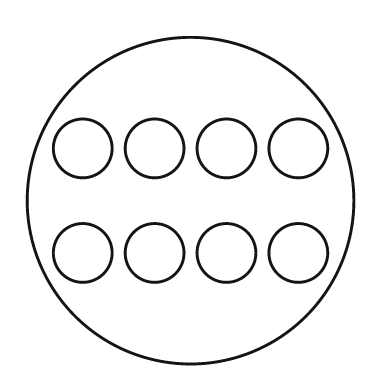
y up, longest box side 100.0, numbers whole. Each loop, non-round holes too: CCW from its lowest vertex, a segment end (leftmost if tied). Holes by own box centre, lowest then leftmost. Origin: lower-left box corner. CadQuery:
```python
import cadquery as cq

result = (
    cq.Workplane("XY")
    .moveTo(50.0, 50.0)
    .circle(50.0)
    .moveTo(17.0, 34.0)
    .circle(9.0)
    .moveTo(39.0, 34.0)
    .circle(9.0)
    .moveTo(61.0, 34.0)
    .circle(9.0)
    .moveTo(83.0, 34.0)
    .circle(9.0)
    .moveTo(17.0, 66.0)
    .circle(9.0)
    .moveTo(39.0, 66.0)
    .circle(9.0)
    .moveTo(61.0, 66.0)
    .circle(9.0)
    .moveTo(83.0, 66.0)
    .circle(9.0)
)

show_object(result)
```